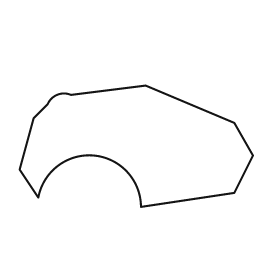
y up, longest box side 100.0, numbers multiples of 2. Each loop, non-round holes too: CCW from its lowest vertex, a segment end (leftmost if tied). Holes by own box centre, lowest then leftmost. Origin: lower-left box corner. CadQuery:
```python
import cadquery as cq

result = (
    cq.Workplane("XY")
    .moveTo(52.0, 0.0)
    .lineTo(92.0, 6.0)
    .lineTo(100.0, 22.0)
    .lineTo(92.0, 36.0)
    .lineTo(54.0, 52.0)
    .lineTo(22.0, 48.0)
    .threePointArc((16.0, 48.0), (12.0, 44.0))
    .lineTo(6.0, 38.0)
    .lineTo(0.0, 16.0)
    .lineTo(8.0, 4.0)
    .threePointArc((32.0, 22.0), (52.0, 0.0))
    .close()
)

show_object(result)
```